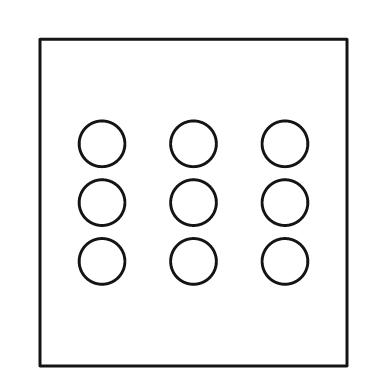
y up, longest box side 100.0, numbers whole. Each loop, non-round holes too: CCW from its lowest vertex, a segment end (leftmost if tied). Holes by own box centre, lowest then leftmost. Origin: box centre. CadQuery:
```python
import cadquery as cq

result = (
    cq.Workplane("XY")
    .moveTo(-47.0, -50.0)
    .lineTo(47.0, -50.0)
    .lineTo(47.0, 50.0)
    .lineTo(-47.0, 50.0)
    .close()
    .moveTo(-28.0, -18.0)
    .circle(7.0)
    .moveTo(0.0, -18.0)
    .circle(7.0)
    .moveTo(28.0, -18.0)
    .circle(7.0)
    .moveTo(-28.0, 0.0)
    .circle(7.0)
    .moveTo(0.0, 0.0)
    .circle(7.0)
    .moveTo(28.0, 0.0)
    .circle(7.0)
    .moveTo(-28.0, 18.0)
    .circle(7.0)
    .moveTo(0.0, 18.0)
    .circle(7.0)
    .moveTo(28.0, 18.0)
    .circle(7.0)
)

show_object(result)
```